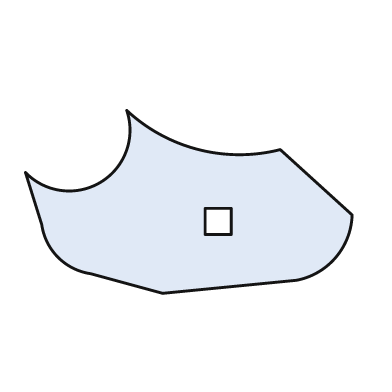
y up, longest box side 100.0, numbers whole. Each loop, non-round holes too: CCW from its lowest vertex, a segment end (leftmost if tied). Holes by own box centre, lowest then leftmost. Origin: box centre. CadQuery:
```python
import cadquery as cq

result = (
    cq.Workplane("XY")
    .moveTo(-8.0, -28.0)
    .lineTo(33.0, -24.0)
    .threePointArc((45.0, -17.0), (50.0, -4.0))
    .lineTo(28.0, 16.0)
    .threePointArc((3.0, 16.0), (-19.0, 28.0))
    .threePointArc((-27.0, 6.0), (-50.0, 9.0))
    .lineTo(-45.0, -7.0)
    .threePointArc((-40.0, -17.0), (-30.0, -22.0))
    .close()
    .moveTo(5.0, -10.0)
    .lineTo(13.0, -10.0)
    .lineTo(13.0, -2.0)
    .lineTo(5.0, -2.0)
    .close()
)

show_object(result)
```